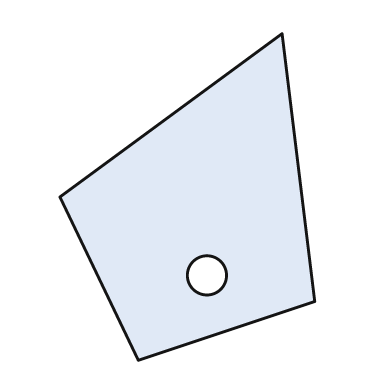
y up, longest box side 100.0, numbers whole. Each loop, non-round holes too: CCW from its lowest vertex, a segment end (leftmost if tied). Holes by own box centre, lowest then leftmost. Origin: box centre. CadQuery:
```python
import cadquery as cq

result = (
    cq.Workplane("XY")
    .moveTo(-15.0, -50.0)
    .lineTo(39.0, -32.0)
    .lineTo(29.0, 50.0)
    .lineTo(-39.0, 0.0)
    .close()
    .moveTo(6.0, -24.0)
    .circle(6.0)
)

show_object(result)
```